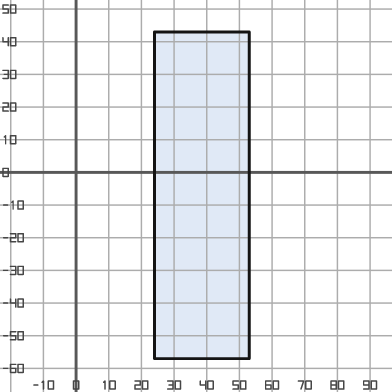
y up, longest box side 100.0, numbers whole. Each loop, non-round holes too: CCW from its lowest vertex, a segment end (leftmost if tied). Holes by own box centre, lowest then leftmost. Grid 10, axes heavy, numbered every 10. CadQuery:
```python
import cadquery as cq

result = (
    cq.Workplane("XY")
    .moveTo(24.0, -57.0)
    .lineTo(53.0, -57.0)
    .lineTo(53.0, 43.0)
    .lineTo(24.0, 43.0)
    .close()
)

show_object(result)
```